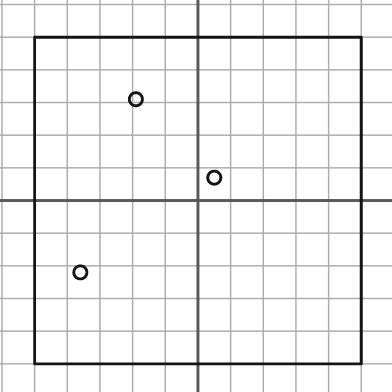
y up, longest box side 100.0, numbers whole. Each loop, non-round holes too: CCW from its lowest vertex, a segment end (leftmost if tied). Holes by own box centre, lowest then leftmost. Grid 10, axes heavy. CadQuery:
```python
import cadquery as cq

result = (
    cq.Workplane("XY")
    .moveTo(-50.0, -50.0)
    .lineTo(50.0, -50.0)
    .lineTo(50.0, 50.0)
    .lineTo(-50.0, 50.0)
    .close()
    .moveTo(-36.0, -22.0)
    .circle(2.0)
    .moveTo(5.0, 7.0)
    .circle(2.0)
    .moveTo(-19.0, 31.0)
    .circle(2.0)
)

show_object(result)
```